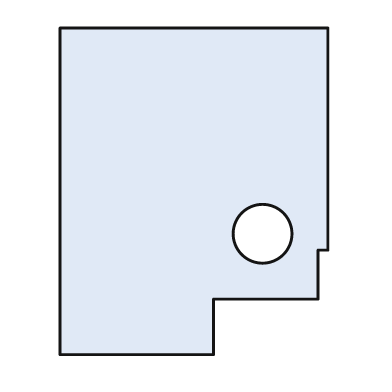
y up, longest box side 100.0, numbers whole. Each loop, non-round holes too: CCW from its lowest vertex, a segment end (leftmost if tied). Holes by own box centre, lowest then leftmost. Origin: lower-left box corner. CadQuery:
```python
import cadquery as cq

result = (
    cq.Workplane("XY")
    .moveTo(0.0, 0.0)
    .lineTo(47.0, 0.0)
    .lineTo(47.0, 17.0)
    .lineTo(79.0, 17.0)
    .lineTo(79.0, 32.0)
    .lineTo(82.0, 32.0)
    .lineTo(82.0, 100.0)
    .lineTo(0.0, 100.0)
    .close()
    .moveTo(62.0, 37.0)
    .circle(9.0)
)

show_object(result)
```